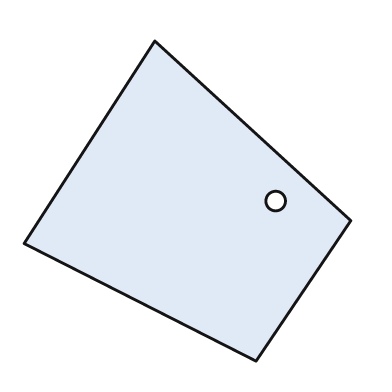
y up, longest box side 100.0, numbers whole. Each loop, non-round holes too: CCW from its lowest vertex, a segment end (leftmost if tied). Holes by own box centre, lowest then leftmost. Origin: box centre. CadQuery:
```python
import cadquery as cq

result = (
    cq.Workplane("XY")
    .moveTo(21.0, -49.0)
    .lineTo(50.0, -6.0)
    .lineTo(-10.0, 49.0)
    .lineTo(-50.0, -13.0)
    .close()
    .moveTo(27.0, 0.0)
    .circle(3.0)
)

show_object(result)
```